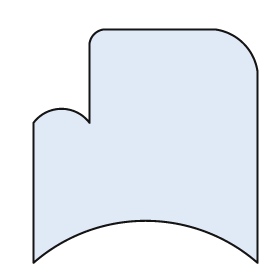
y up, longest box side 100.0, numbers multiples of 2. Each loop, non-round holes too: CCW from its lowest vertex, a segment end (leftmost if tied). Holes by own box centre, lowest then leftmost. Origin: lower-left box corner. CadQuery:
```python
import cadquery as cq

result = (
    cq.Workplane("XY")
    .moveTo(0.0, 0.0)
    .threePointArc((48.0, 18.0), (96.0, 0.0))
    .lineTo(96.0, 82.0)
    .threePointArc((90.0, 94.0), (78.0, 100.0))
    .lineTo(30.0, 100.0)
    .threePointArc((26.0, 98.0), (24.0, 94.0))
    .lineTo(24.0, 60.0)
    .threePointArc((12.0, 66.0), (0.0, 60.0))
    .close()
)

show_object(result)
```